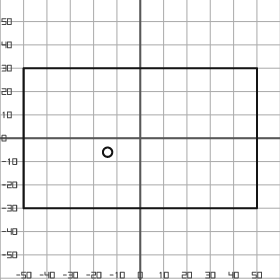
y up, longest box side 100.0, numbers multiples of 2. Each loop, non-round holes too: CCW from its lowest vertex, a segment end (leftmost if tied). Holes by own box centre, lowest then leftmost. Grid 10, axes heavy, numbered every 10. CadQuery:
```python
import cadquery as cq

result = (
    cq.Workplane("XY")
    .moveTo(-50.0, -30.0)
    .lineTo(50.0, -30.0)
    .lineTo(50.0, 30.0)
    .lineTo(-50.0, 30.0)
    .close()
    .moveTo(-14.0, -6.0)
    .circle(2.0)
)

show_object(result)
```